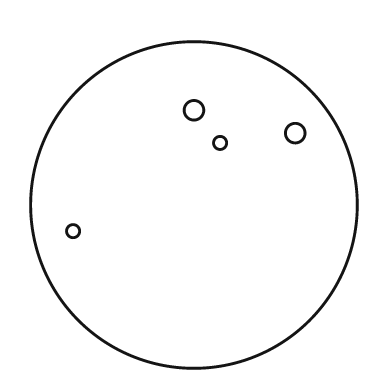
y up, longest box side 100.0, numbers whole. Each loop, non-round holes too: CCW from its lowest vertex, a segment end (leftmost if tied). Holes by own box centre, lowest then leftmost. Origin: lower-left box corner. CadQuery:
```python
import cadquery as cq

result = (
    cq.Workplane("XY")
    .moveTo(50.0, 50.0)
    .circle(50.0)
    .moveTo(13.0, 42.0)
    .circle(2.0)
    .moveTo(58.0, 69.0)
    .circle(2.0)
    .moveTo(81.0, 72.0)
    .circle(3.0)
    .moveTo(50.0, 79.0)
    .circle(3.0)
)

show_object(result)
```